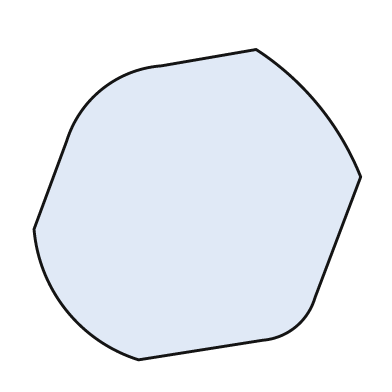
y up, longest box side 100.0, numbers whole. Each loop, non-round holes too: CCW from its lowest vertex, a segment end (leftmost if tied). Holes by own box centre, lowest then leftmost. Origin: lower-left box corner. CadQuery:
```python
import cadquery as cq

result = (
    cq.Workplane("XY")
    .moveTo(32.0, 0.0)
    .lineTo(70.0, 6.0)
    .threePointArc((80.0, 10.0), (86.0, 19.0))
    .lineTo(100.0, 56.0)
    .threePointArc((87.0, 78.0), (68.0, 95.0))
    .lineTo(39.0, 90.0)
    .threePointArc((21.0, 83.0), (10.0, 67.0))
    .lineTo(0.0, 40.0)
    .threePointArc((10.0, 15.0), (32.0, 0.0))
    .close()
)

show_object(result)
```